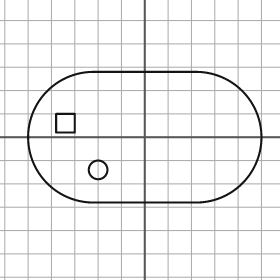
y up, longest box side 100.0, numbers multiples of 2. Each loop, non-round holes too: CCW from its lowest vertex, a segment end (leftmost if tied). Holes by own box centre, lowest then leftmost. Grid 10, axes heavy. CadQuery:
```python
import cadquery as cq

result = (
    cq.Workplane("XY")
    .moveTo(-22.0, -28.0)
    .lineTo(22.0, -28.0)
    .threePointArc((50.0, 0.0), (22.0, 28.0))
    .lineTo(-22.0, 28.0)
    .threePointArc((-50.0, 0.0), (-22.0, -28.0))
    .close()
    .moveTo(-20.0, -14.0)
    .circle(4.0)
    .moveTo(-38.0, 2.0)
    .lineTo(-30.0, 2.0)
    .lineTo(-30.0, 10.0)
    .lineTo(-38.0, 10.0)
    .close()
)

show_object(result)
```